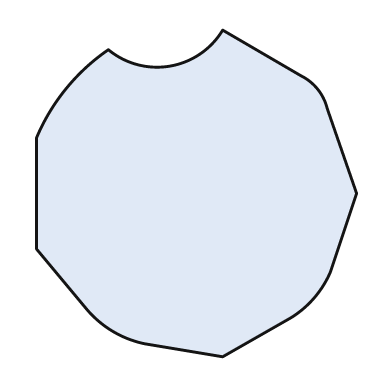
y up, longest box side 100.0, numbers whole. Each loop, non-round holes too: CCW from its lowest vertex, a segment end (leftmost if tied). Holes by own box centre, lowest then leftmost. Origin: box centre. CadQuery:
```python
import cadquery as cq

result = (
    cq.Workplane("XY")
    .moveTo(8.0, -50.0)
    .lineTo(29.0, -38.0)
    .threePointArc((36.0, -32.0), (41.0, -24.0))
    .lineTo(49.0, 0.0)
    .lineTo(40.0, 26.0)
    .threePointArc((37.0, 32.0), (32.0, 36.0))
    .lineTo(8.0, 50.0)
    .threePointArc((-8.0, 39.0), (-27.0, 44.0))
    .threePointArc((-40.0, 32.0), (-49.0, 17.0))
    .lineTo(-49.0, -17.0)
    .lineTo(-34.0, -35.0)
    .threePointArc((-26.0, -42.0), (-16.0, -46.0))
    .close()
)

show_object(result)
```